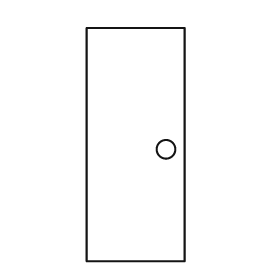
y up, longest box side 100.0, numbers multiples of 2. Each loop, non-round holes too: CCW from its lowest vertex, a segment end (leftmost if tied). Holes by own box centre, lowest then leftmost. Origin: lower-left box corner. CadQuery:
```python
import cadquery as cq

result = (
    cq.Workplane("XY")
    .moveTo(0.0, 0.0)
    .lineTo(42.0, 0.0)
    .lineTo(42.0, 100.0)
    .lineTo(0.0, 100.0)
    .close()
    .moveTo(34.0, 48.0)
    .circle(4.0)
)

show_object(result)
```